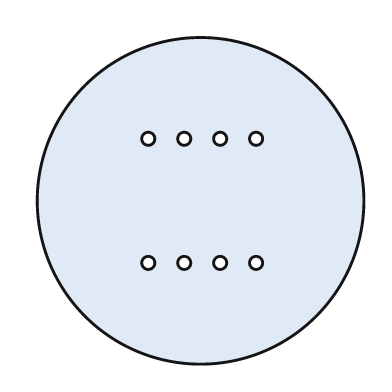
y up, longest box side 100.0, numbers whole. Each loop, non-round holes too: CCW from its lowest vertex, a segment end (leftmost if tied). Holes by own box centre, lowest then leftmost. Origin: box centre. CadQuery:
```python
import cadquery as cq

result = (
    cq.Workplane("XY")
    .moveTo(0.0, 0.0)
    .circle(50.0)
    .moveTo(-16.0, -19.0)
    .circle(2.0)
    .moveTo(-5.0, -19.0)
    .circle(2.0)
    .moveTo(6.0, -19.0)
    .circle(2.0)
    .moveTo(17.0, -19.0)
    .circle(2.0)
    .moveTo(-16.0, 19.0)
    .circle(2.0)
    .moveTo(-5.0, 19.0)
    .circle(2.0)
    .moveTo(6.0, 19.0)
    .circle(2.0)
    .moveTo(17.0, 19.0)
    .circle(2.0)
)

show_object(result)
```